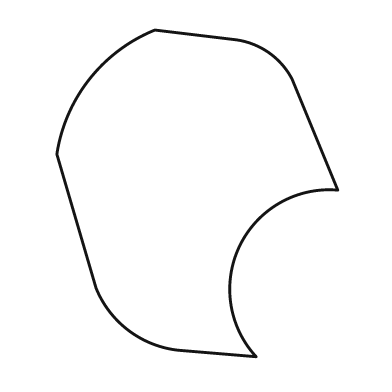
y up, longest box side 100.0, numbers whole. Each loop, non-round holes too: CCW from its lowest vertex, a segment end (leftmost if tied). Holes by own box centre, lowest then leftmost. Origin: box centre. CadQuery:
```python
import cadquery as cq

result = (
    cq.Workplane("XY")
    .moveTo(18.0, -50.0)
    .threePointArc((13.0, -16.0), (43.0, 1.0))
    .lineTo(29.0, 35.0)
    .threePointArc((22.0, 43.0), (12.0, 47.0))
    .lineTo(-13.0, 50.0)
    .threePointArc((-33.0, 35.0), (-43.0, 12.0))
    .lineTo(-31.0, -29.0)
    .threePointArc((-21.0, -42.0), (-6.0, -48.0))
    .close()
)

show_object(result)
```